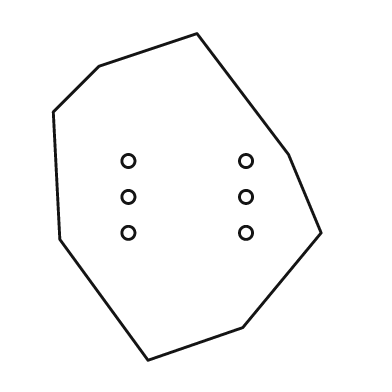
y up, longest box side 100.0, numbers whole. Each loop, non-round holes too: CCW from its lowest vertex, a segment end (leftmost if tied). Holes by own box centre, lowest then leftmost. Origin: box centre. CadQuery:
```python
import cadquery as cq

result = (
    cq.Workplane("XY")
    .moveTo(-12.0, -50.0)
    .lineTo(17.0, -40.0)
    .lineTo(41.0, -11.0)
    .lineTo(31.0, 13.0)
    .lineTo(3.0, 50.0)
    .lineTo(-27.0, 40.0)
    .lineTo(-41.0, 26.0)
    .lineTo(-39.0, -13.0)
    .close()
    .moveTo(-18.0, -11.0)
    .circle(2.0)
    .moveTo(18.0, -11.0)
    .circle(2.0)
    .moveTo(-18.0, 0.0)
    .circle(2.0)
    .moveTo(18.0, 0.0)
    .circle(2.0)
    .moveTo(-18.0, 11.0)
    .circle(2.0)
    .moveTo(18.0, 11.0)
    .circle(2.0)
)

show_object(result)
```